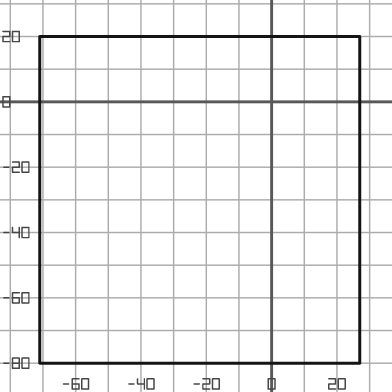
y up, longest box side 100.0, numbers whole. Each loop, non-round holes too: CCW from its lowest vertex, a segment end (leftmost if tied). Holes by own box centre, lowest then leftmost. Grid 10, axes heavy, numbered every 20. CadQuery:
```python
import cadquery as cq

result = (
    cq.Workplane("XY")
    .moveTo(-71.0, -80.0)
    .lineTo(27.0, -80.0)
    .lineTo(27.0, 20.0)
    .lineTo(-71.0, 20.0)
    .close()
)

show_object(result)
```